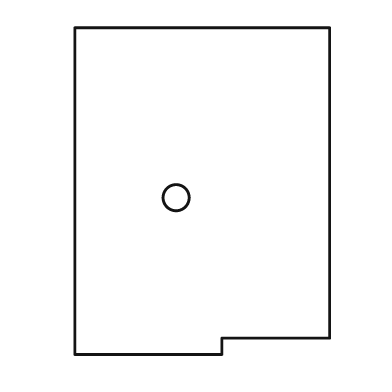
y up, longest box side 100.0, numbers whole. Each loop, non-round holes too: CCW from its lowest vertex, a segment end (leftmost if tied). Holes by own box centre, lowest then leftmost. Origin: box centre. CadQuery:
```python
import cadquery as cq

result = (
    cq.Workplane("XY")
    .moveTo(-39.0, -50.0)
    .lineTo(6.0, -50.0)
    .lineTo(6.0, -45.0)
    .lineTo(39.0, -45.0)
    .lineTo(39.0, 50.0)
    .lineTo(-39.0, 50.0)
    .close()
    .moveTo(-8.0, -2.0)
    .circle(4.0)
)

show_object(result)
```